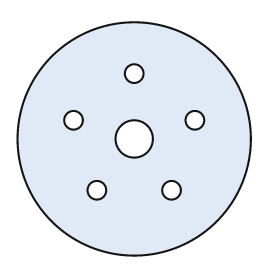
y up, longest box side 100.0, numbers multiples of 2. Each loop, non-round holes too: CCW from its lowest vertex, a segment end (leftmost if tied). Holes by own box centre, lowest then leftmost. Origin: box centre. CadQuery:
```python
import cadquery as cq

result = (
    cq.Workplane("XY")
    .moveTo(0.0, 0.0)
    .circle(50.0)
    .moveTo(-16.0, -22.0)
    .circle(4.0)
    .moveTo(16.0, -22.0)
    .circle(4.0)
    .moveTo(0.0, 0.0)
    .circle(8.0)
    .moveTo(-26.0, 8.0)
    .circle(4.0)
    .moveTo(26.0, 8.0)
    .circle(4.0)
    .moveTo(0.0, 28.0)
    .circle(4.0)
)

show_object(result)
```